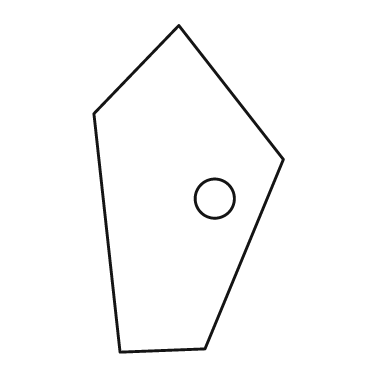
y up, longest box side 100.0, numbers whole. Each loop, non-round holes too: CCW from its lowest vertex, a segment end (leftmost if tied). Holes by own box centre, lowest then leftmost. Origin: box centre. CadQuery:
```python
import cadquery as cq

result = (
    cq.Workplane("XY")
    .moveTo(-21.0, -50.0)
    .lineTo(5.0, -49.0)
    .lineTo(29.0, 9.0)
    .lineTo(-3.0, 50.0)
    .lineTo(-29.0, 23.0)
    .close()
    .moveTo(8.0, -3.0)
    .circle(6.0)
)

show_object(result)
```